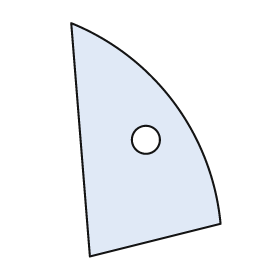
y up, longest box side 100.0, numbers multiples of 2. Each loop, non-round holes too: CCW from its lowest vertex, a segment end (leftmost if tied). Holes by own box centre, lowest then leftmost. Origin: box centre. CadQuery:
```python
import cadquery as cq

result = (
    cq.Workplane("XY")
    .moveTo(-24.0, -50.0)
    .lineTo(32.0, -36.0)
    .threePointArc((12.0, 16.0), (-32.0, 50.0))
    .close()
    .moveTo(0.0, 0.0)
    .circle(6.0)
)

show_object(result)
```